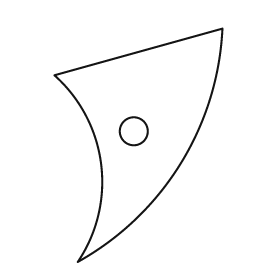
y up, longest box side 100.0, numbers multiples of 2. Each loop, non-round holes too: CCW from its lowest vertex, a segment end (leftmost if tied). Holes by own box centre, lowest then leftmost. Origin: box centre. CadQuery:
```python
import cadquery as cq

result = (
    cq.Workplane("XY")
    .moveTo(-26.0, -50.0)
    .threePointArc((18.0, -8.0), (36.0, 50.0))
    .lineTo(-36.0, 30.0)
    .threePointArc((-16.0, -8.0), (-26.0, -50.0))
    .close()
    .moveTo(-2.0, 6.0)
    .circle(6.0)
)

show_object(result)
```